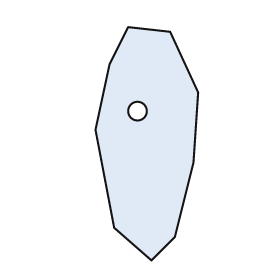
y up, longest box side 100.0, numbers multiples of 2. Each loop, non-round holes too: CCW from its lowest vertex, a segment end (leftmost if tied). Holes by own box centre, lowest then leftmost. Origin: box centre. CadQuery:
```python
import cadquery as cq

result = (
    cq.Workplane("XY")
    .moveTo(2.0, -50.0)
    .lineTo(12.0, -40.0)
    .lineTo(20.0, -8.0)
    .lineTo(22.0, 22.0)
    .lineTo(10.0, 48.0)
    .lineTo(-8.0, 50.0)
    .lineTo(-16.0, 34.0)
    .lineTo(-22.0, 6.0)
    .lineTo(-14.0, -36.0)
    .close()
    .moveTo(-4.0, 14.0)
    .circle(4.0)
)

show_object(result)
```